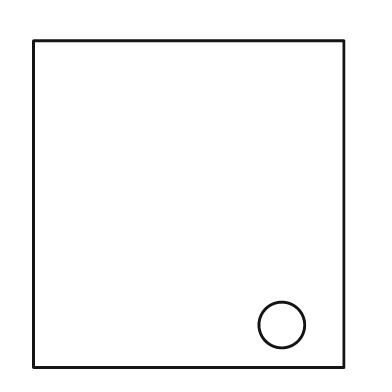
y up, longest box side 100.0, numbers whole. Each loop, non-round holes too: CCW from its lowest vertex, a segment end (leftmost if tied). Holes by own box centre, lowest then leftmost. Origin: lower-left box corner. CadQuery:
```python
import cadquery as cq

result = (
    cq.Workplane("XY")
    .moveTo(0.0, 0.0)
    .lineTo(95.0, 0.0)
    .lineTo(95.0, 100.0)
    .lineTo(0.0, 100.0)
    .close()
    .moveTo(76.0, 13.0)
    .circle(7.0)
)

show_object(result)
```